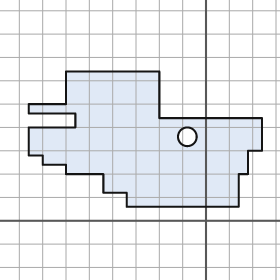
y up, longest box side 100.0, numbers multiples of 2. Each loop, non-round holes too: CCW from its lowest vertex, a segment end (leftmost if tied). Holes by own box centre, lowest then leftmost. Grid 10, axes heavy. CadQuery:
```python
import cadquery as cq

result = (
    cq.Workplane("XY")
    .moveTo(-34.0, 6.0)
    .lineTo(14.0, 6.0)
    .lineTo(14.0, 20.0)
    .lineTo(18.0, 20.0)
    .lineTo(18.0, 30.0)
    .lineTo(24.0, 30.0)
    .lineTo(24.0, 44.0)
    .lineTo(-20.0, 44.0)
    .lineTo(-20.0, 64.0)
    .lineTo(-60.0, 64.0)
    .lineTo(-60.0, 50.0)
    .lineTo(-76.0, 50.0)
    .lineTo(-76.0, 46.0)
    .lineTo(-56.0, 46.0)
    .lineTo(-56.0, 40.0)
    .lineTo(-76.0, 40.0)
    .lineTo(-76.0, 28.0)
    .lineTo(-70.0, 28.0)
    .lineTo(-70.0, 24.0)
    .lineTo(-60.0, 24.0)
    .lineTo(-60.0, 20.0)
    .lineTo(-44.0, 20.0)
    .lineTo(-44.0, 12.0)
    .lineTo(-34.0, 12.0)
    .close()
    .moveTo(-8.0, 36.0)
    .circle(4.0)
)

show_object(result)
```